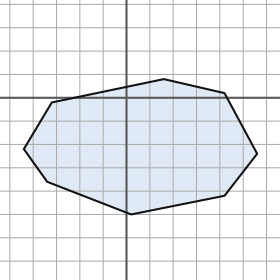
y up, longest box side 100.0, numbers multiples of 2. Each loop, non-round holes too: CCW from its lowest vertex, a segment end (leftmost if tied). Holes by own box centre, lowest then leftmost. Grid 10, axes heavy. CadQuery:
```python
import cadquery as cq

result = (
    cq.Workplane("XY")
    .moveTo(2.0, -50.0)
    .lineTo(42.0, -42.0)
    .lineTo(56.0, -24.0)
    .lineTo(42.0, 2.0)
    .lineTo(16.0, 8.0)
    .lineTo(-32.0, -2.0)
    .lineTo(-44.0, -22.0)
    .lineTo(-34.0, -36.0)
    .close()
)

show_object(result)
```